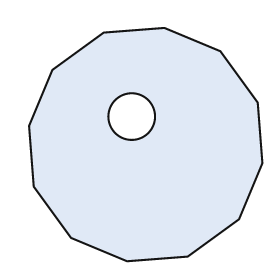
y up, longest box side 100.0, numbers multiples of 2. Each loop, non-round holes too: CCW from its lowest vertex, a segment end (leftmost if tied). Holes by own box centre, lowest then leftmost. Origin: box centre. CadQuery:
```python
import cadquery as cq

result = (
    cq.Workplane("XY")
    .moveTo(-8.0, -50.0)
    .lineTo(18.0, -48.0)
    .lineTo(40.0, -32.0)
    .lineTo(50.0, -8.0)
    .lineTo(48.0, 18.0)
    .lineTo(32.0, 40.0)
    .lineTo(8.0, 50.0)
    .lineTo(-18.0, 48.0)
    .lineTo(-40.0, 32.0)
    .lineTo(-50.0, 8.0)
    .lineTo(-48.0, -18.0)
    .lineTo(-32.0, -40.0)
    .close()
    .moveTo(-6.0, 12.0)
    .circle(10.0)
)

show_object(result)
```